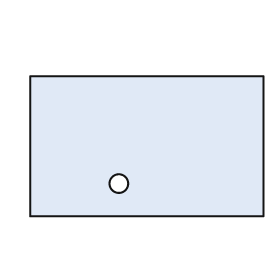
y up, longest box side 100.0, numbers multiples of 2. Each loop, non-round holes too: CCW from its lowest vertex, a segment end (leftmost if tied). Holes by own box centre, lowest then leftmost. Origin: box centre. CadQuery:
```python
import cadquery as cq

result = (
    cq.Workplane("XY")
    .moveTo(-50.0, -30.0)
    .lineTo(50.0, -30.0)
    .lineTo(50.0, 30.0)
    .lineTo(-50.0, 30.0)
    .close()
    .moveTo(-12.0, -16.0)
    .circle(4.0)
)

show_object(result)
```